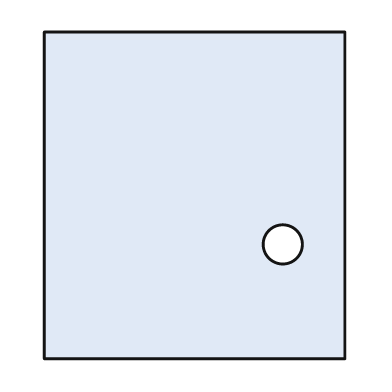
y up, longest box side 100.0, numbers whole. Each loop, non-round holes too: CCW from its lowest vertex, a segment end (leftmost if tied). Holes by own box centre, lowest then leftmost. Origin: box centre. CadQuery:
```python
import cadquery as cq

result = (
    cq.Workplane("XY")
    .moveTo(-46.0, -50.0)
    .lineTo(46.0, -50.0)
    .lineTo(46.0, 50.0)
    .lineTo(-46.0, 50.0)
    .close()
    .moveTo(27.0, -15.0)
    .circle(6.0)
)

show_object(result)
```